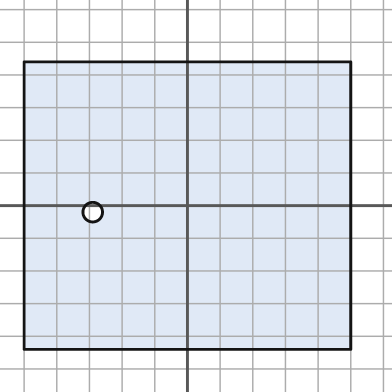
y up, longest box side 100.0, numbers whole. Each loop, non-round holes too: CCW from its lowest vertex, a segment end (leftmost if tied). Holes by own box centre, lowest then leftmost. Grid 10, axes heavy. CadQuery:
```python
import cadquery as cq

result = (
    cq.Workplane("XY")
    .moveTo(-50.0, -44.0)
    .lineTo(50.0, -44.0)
    .lineTo(50.0, 44.0)
    .lineTo(-50.0, 44.0)
    .close()
    .moveTo(-29.0, -2.0)
    .circle(3.0)
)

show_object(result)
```